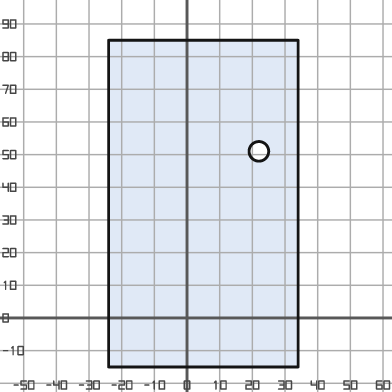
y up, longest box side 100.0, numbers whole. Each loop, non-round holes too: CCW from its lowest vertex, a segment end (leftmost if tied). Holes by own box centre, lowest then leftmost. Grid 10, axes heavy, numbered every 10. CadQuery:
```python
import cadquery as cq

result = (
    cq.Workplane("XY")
    .moveTo(-24.0, -15.0)
    .lineTo(34.0, -15.0)
    .lineTo(34.0, 85.0)
    .lineTo(-24.0, 85.0)
    .close()
    .moveTo(22.0, 51.0)
    .circle(3.0)
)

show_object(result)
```